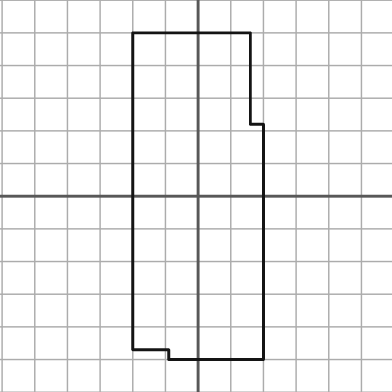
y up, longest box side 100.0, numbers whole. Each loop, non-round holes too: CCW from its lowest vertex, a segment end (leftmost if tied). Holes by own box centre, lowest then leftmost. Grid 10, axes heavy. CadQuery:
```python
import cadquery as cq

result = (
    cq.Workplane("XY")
    .moveTo(-9.0, -50.0)
    .lineTo(20.0, -50.0)
    .lineTo(20.0, 22.0)
    .lineTo(16.0, 22.0)
    .lineTo(16.0, 50.0)
    .lineTo(-20.0, 50.0)
    .lineTo(-20.0, -47.0)
    .lineTo(-9.0, -47.0)
    .close()
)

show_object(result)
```